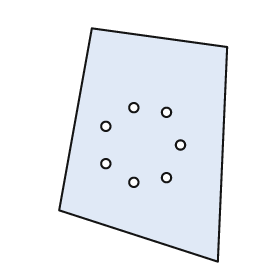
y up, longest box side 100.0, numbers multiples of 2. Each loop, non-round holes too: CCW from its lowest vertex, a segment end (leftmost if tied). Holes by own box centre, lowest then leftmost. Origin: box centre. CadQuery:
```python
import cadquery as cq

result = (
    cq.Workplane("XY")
    .moveTo(32.0, -50.0)
    .lineTo(36.0, 42.0)
    .lineTo(-22.0, 50.0)
    .lineTo(-36.0, -28.0)
    .close()
    .moveTo(-4.0, -16.0)
    .circle(2.0)
    .moveTo(10.0, -14.0)
    .circle(2.0)
    .moveTo(-16.0, -8.0)
    .circle(2.0)
    .moveTo(16.0, 0.0)
    .circle(2.0)
    .moveTo(-16.0, 8.0)
    .circle(2.0)
    .moveTo(10.0, 14.0)
    .circle(2.0)
    .moveTo(-4.0, 16.0)
    .circle(2.0)
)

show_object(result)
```